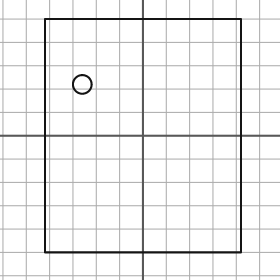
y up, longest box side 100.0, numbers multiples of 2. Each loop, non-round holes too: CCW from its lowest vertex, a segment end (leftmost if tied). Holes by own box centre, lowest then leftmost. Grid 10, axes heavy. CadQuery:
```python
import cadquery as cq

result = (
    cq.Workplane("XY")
    .moveTo(-42.0, -50.0)
    .lineTo(42.0, -50.0)
    .lineTo(42.0, 50.0)
    .lineTo(-42.0, 50.0)
    .close()
    .moveTo(-26.0, 22.0)
    .circle(4.0)
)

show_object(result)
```